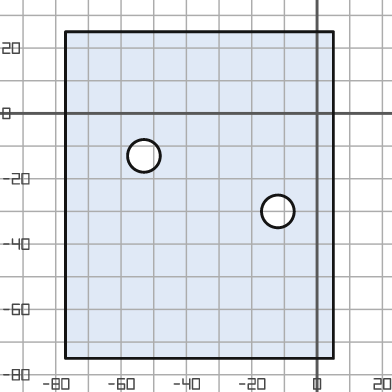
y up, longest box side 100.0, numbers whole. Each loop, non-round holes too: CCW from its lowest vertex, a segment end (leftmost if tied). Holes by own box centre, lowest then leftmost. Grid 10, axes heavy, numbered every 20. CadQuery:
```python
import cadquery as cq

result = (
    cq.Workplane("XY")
    .moveTo(-77.0, -75.0)
    .lineTo(5.0, -75.0)
    .lineTo(5.0, 25.0)
    .lineTo(-77.0, 25.0)
    .close()
    .moveTo(-12.0, -30.0)
    .circle(5.0)
    .moveTo(-53.0, -13.0)
    .circle(5.0)
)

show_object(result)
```